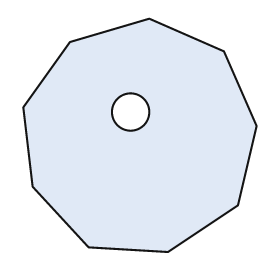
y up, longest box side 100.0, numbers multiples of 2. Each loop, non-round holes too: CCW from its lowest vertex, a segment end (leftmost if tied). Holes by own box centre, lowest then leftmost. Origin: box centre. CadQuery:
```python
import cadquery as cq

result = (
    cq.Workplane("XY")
    .moveTo(12.0, -50.0)
    .lineTo(42.0, -30.0)
    .lineTo(50.0, 4.0)
    .lineTo(36.0, 36.0)
    .lineTo(4.0, 50.0)
    .lineTo(-30.0, 40.0)
    .lineTo(-50.0, 12.0)
    .lineTo(-46.0, -22.0)
    .lineTo(-22.0, -48.0)
    .close()
    .moveTo(-4.0, 10.0)
    .circle(8.0)
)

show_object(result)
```